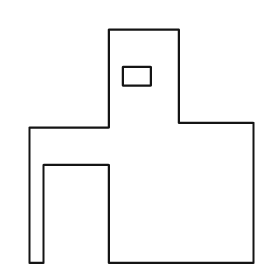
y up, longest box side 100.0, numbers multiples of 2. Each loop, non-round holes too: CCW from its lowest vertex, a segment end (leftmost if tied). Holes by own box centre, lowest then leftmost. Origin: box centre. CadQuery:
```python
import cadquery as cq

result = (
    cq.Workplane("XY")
    .moveTo(-48.0, -50.0)
    .lineTo(-42.0, -50.0)
    .lineTo(-42.0, -8.0)
    .lineTo(-14.0, -8.0)
    .lineTo(-14.0, -50.0)
    .lineTo(48.0, -50.0)
    .lineTo(48.0, 10.0)
    .lineTo(16.0, 10.0)
    .lineTo(16.0, 50.0)
    .lineTo(-14.0, 50.0)
    .lineTo(-14.0, 8.0)
    .lineTo(-48.0, 8.0)
    .close()
    .moveTo(-8.0, 26.0)
    .lineTo(4.0, 26.0)
    .lineTo(4.0, 34.0)
    .lineTo(-8.0, 34.0)
    .close()
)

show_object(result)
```